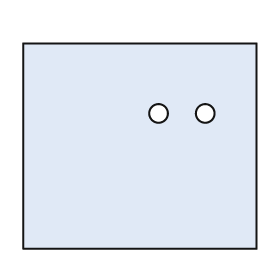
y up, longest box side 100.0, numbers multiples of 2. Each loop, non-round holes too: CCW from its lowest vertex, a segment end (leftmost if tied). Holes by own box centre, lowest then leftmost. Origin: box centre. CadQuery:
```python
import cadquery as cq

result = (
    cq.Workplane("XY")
    .moveTo(-50.0, -44.0)
    .lineTo(50.0, -44.0)
    .lineTo(50.0, 44.0)
    .lineTo(-50.0, 44.0)
    .close()
    .moveTo(8.0, 14.0)
    .circle(4.0)
    .moveTo(28.0, 14.0)
    .circle(4.0)
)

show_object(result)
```